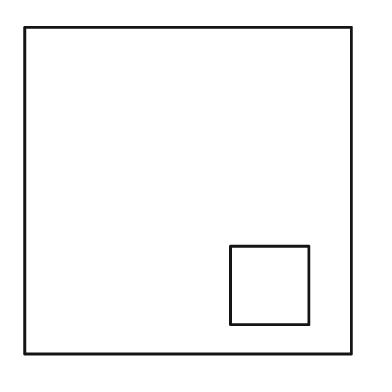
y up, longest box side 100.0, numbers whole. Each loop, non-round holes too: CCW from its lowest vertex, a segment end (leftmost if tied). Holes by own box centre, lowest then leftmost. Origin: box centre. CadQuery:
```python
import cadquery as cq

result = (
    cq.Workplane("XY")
    .moveTo(-50.0, -50.0)
    .lineTo(50.0, -50.0)
    .lineTo(50.0, 50.0)
    .lineTo(-50.0, 50.0)
    .close()
    .moveTo(13.0, -41.0)
    .lineTo(37.0, -41.0)
    .lineTo(37.0, -17.0)
    .lineTo(13.0, -17.0)
    .close()
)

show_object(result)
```